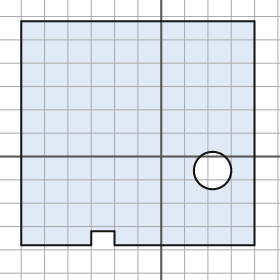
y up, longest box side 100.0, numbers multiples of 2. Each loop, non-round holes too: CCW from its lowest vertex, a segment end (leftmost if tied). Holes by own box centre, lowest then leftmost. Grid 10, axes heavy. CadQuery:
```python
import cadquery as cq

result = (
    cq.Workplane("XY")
    .moveTo(-60.0, -38.0)
    .lineTo(-30.0, -38.0)
    .lineTo(-30.0, -32.0)
    .lineTo(-20.0, -32.0)
    .lineTo(-20.0, -38.0)
    .lineTo(40.0, -38.0)
    .lineTo(40.0, 58.0)
    .lineTo(-60.0, 58.0)
    .close()
    .moveTo(22.0, -6.0)
    .circle(8.0)
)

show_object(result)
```